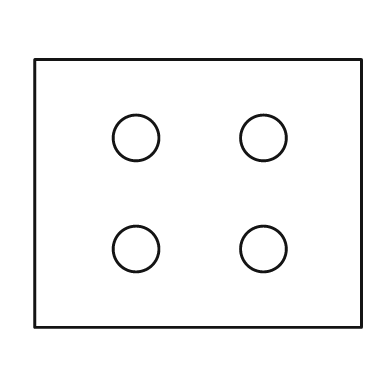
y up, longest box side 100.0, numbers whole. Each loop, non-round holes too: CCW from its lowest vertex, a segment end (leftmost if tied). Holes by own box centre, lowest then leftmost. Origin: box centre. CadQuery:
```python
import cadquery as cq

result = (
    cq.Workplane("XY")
    .moveTo(-50.0, -41.0)
    .lineTo(50.0, -41.0)
    .lineTo(50.0, 41.0)
    .lineTo(-50.0, 41.0)
    .close()
    .moveTo(-19.0, -17.0)
    .circle(7.0)
    .moveTo(20.0, -17.0)
    .circle(7.0)
    .moveTo(-19.0, 17.0)
    .circle(7.0)
    .moveTo(20.0, 17.0)
    .circle(7.0)
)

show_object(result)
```